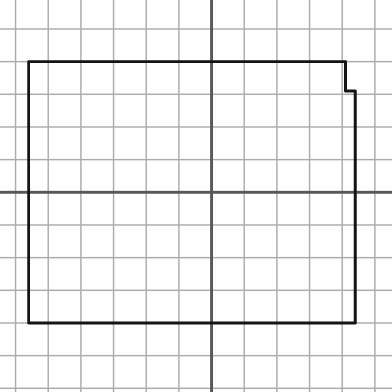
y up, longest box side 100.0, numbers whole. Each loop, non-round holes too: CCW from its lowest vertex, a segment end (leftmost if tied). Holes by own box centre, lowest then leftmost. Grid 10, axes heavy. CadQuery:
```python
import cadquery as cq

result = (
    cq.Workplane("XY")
    .moveTo(-56.0, -40.0)
    .lineTo(44.0, -40.0)
    .lineTo(44.0, 31.0)
    .lineTo(41.0, 31.0)
    .lineTo(41.0, 40.0)
    .lineTo(-56.0, 40.0)
    .close()
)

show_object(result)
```